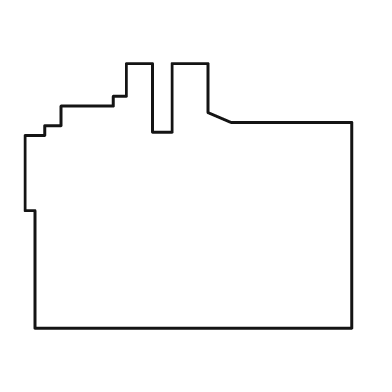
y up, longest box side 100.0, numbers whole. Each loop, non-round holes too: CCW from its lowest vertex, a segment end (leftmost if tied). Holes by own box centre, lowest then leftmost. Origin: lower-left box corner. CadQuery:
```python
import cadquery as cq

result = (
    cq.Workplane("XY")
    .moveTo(3.0, 0.0)
    .lineTo(100.0, 0.0)
    .lineTo(100.0, 63.0)
    .lineTo(63.0, 63.0)
    .lineTo(56.0, 66.0)
    .lineTo(56.0, 81.0)
    .lineTo(45.0, 81.0)
    .lineTo(45.0, 60.0)
    .lineTo(39.0, 60.0)
    .lineTo(39.0, 81.0)
    .lineTo(31.0, 81.0)
    .lineTo(31.0, 71.0)
    .lineTo(27.0, 71.0)
    .lineTo(27.0, 68.0)
    .lineTo(11.0, 68.0)
    .lineTo(11.0, 62.0)
    .lineTo(6.0, 62.0)
    .lineTo(6.0, 59.0)
    .lineTo(0.0, 59.0)
    .lineTo(0.0, 36.0)
    .lineTo(3.0, 36.0)
    .close()
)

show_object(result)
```